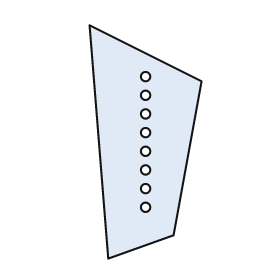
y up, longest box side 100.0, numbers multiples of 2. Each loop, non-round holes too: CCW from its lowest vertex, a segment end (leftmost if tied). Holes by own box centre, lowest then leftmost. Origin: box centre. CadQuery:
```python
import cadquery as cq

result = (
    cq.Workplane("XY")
    .moveTo(-16.0, -50.0)
    .lineTo(12.0, -40.0)
    .lineTo(24.0, 26.0)
    .lineTo(-24.0, 50.0)
    .close()
    .moveTo(0.0, -28.0)
    .circle(2.0)
    .moveTo(0.0, -20.0)
    .circle(2.0)
    .moveTo(0.0, -12.0)
    .circle(2.0)
    .moveTo(0.0, -4.0)
    .circle(2.0)
    .moveTo(0.0, 4.0)
    .circle(2.0)
    .moveTo(0.0, 12.0)
    .circle(2.0)
    .moveTo(0.0, 20.0)
    .circle(2.0)
    .moveTo(0.0, 28.0)
    .circle(2.0)
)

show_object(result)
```